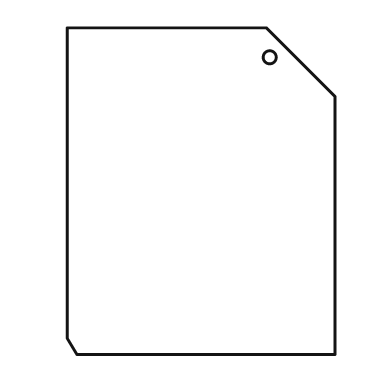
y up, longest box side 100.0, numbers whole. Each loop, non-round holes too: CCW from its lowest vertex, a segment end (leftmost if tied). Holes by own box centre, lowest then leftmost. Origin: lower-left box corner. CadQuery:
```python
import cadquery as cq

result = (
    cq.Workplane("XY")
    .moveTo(3.0, 0.0)
    .lineTo(82.0, 0.0)
    .lineTo(82.0, 79.0)
    .lineTo(61.0, 100.0)
    .lineTo(0.0, 100.0)
    .lineTo(0.0, 5.0)
    .close()
    .moveTo(62.0, 91.0)
    .circle(2.0)
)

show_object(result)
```